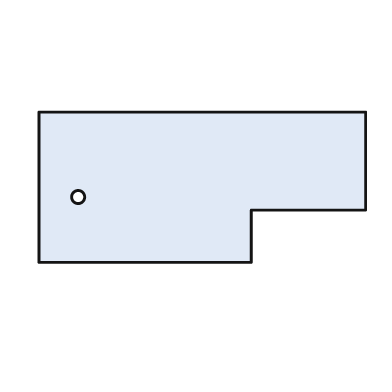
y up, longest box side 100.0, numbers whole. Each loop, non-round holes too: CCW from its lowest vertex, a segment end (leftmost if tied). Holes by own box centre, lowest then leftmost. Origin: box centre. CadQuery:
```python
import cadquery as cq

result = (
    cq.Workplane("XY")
    .moveTo(-50.0, -23.0)
    .lineTo(15.0, -23.0)
    .lineTo(15.0, -7.0)
    .lineTo(50.0, -7.0)
    .lineTo(50.0, 23.0)
    .lineTo(-50.0, 23.0)
    .close()
    .moveTo(-38.0, -3.0)
    .circle(2.0)
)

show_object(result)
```